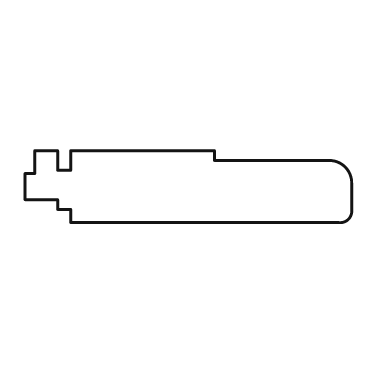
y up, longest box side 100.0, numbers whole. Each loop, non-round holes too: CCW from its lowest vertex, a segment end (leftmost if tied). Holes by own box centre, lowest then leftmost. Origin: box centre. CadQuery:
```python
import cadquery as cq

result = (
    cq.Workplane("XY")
    .moveTo(-36.0, -11.0)
    .lineTo(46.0, -11.0)
    .threePointArc((49.0, -10.0), (50.0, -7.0))
    .lineTo(50.0, 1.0)
    .threePointArc((48.0, 6.0), (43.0, 8.0))
    .lineTo(8.0, 8.0)
    .lineTo(8.0, 11.0)
    .lineTo(-36.0, 11.0)
    .lineTo(-36.0, 5.0)
    .lineTo(-40.0, 5.0)
    .lineTo(-40.0, 11.0)
    .lineTo(-47.0, 11.0)
    .lineTo(-47.0, 4.0)
    .lineTo(-50.0, 4.0)
    .lineTo(-50.0, -4.0)
    .lineTo(-40.0, -4.0)
    .lineTo(-40.0, -7.0)
    .lineTo(-36.0, -7.0)
    .close()
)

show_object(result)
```